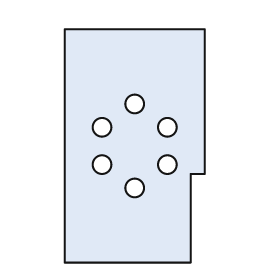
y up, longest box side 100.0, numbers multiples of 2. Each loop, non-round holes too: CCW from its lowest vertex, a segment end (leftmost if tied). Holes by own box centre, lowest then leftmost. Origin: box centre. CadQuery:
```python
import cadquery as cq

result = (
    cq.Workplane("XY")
    .moveTo(-30.0, -50.0)
    .lineTo(24.0, -50.0)
    .lineTo(24.0, -12.0)
    .lineTo(30.0, -12.0)
    .lineTo(30.0, 50.0)
    .lineTo(-30.0, 50.0)
    .close()
    .moveTo(0.0, -18.0)
    .circle(4.0)
    .moveTo(-14.0, -8.0)
    .circle(4.0)
    .moveTo(14.0, -8.0)
    .circle(4.0)
    .moveTo(-14.0, 8.0)
    .circle(4.0)
    .moveTo(14.0, 8.0)
    .circle(4.0)
    .moveTo(0.0, 18.0)
    .circle(4.0)
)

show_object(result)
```